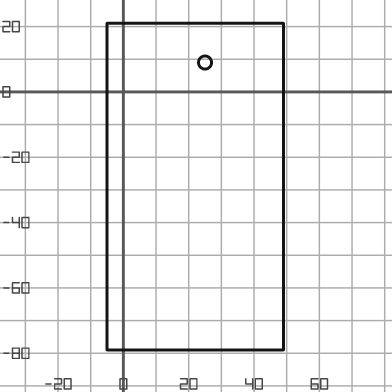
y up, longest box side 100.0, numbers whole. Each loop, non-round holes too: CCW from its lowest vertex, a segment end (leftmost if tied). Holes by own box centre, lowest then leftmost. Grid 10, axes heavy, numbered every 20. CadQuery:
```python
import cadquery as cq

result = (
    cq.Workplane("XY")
    .moveTo(-5.0, -79.0)
    .lineTo(49.0, -79.0)
    .lineTo(49.0, 21.0)
    .lineTo(-5.0, 21.0)
    .close()
    .moveTo(25.0, 9.0)
    .circle(2.0)
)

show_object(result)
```